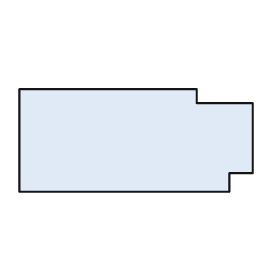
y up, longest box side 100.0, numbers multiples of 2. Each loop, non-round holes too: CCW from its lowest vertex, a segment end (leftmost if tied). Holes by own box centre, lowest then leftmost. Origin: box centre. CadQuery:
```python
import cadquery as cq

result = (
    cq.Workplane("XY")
    .moveTo(-50.0, -22.0)
    .lineTo(40.0, -22.0)
    .lineTo(40.0, -14.0)
    .lineTo(50.0, -14.0)
    .lineTo(50.0, 16.0)
    .lineTo(26.0, 16.0)
    .lineTo(26.0, 22.0)
    .lineTo(-50.0, 22.0)
    .close()
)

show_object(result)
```